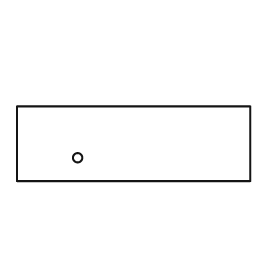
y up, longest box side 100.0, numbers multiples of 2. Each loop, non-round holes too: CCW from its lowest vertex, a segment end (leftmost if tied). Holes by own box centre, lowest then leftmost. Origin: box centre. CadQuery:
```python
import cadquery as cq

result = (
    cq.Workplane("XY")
    .moveTo(-50.0, -16.0)
    .lineTo(50.0, -16.0)
    .lineTo(50.0, 16.0)
    .lineTo(-50.0, 16.0)
    .close()
    .moveTo(-24.0, -6.0)
    .circle(2.0)
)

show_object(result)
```